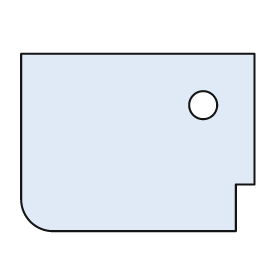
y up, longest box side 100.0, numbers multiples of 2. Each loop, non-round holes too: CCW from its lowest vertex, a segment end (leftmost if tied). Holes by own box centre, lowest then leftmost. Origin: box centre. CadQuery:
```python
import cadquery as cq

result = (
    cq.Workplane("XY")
    .moveTo(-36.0, -38.0)
    .lineTo(42.0, -38.0)
    .lineTo(42.0, -18.0)
    .lineTo(50.0, -18.0)
    .lineTo(50.0, 38.0)
    .lineTo(-50.0, 38.0)
    .lineTo(-50.0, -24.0)
    .threePointArc((-46.0, -34.0), (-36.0, -38.0))
    .close()
    .moveTo(28.0, 16.0)
    .circle(6.0)
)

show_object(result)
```